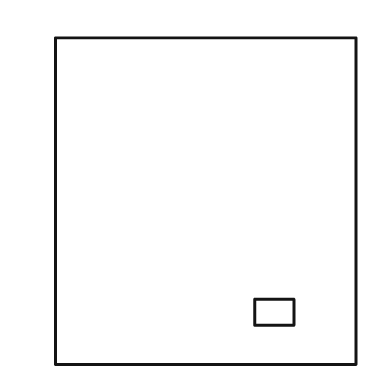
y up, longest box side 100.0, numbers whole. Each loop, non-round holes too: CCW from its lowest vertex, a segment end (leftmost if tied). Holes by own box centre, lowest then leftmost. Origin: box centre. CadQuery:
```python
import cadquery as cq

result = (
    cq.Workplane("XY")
    .moveTo(-46.0, -50.0)
    .lineTo(46.0, -50.0)
    .lineTo(46.0, 50.0)
    .lineTo(-46.0, 50.0)
    .close()
    .moveTo(15.0, -38.0)
    .lineTo(27.0, -38.0)
    .lineTo(27.0, -30.0)
    .lineTo(15.0, -30.0)
    .close()
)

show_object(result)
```